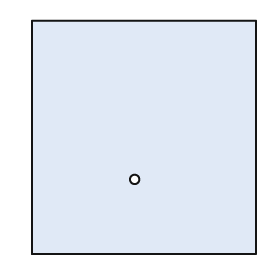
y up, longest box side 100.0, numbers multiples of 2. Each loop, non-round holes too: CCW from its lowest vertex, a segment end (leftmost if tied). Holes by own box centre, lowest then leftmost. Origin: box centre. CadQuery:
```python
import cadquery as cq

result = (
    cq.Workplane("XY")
    .moveTo(-48.0, -50.0)
    .lineTo(48.0, -50.0)
    .lineTo(48.0, 50.0)
    .lineTo(-48.0, 50.0)
    .close()
    .moveTo(-4.0, -18.0)
    .circle(2.0)
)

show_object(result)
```